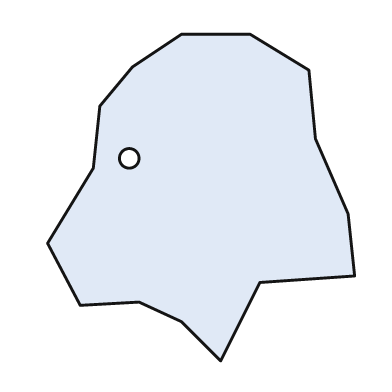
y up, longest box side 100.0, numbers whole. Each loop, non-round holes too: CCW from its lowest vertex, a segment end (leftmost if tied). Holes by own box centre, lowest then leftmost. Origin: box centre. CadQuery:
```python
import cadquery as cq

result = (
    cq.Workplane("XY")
    .moveTo(6.0, -50.0)
    .lineTo(18.0, -26.0)
    .lineTo(47.0, -24.0)
    .lineTo(45.0, -5.0)
    .lineTo(35.0, 18.0)
    .lineTo(33.0, 39.0)
    .lineTo(15.0, 50.0)
    .lineTo(-6.0, 50.0)
    .lineTo(-21.0, 40.0)
    .lineTo(-31.0, 28.0)
    .lineTo(-33.0, 9.0)
    .lineTo(-47.0, -14.0)
    .lineTo(-37.0, -33.0)
    .lineTo(-19.0, -32.0)
    .lineTo(-6.0, -38.0)
    .close()
    .moveTo(-22.0, 12.0)
    .circle(3.0)
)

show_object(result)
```